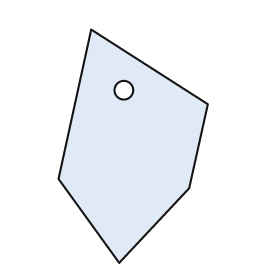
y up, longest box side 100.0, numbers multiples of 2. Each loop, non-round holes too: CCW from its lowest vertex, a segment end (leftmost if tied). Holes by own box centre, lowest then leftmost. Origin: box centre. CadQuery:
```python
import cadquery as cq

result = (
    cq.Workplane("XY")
    .moveTo(-6.0, -50.0)
    .lineTo(24.0, -18.0)
    .lineTo(32.0, 18.0)
    .lineTo(-18.0, 50.0)
    .lineTo(-32.0, -14.0)
    .close()
    .moveTo(-4.0, 24.0)
    .circle(4.0)
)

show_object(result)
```